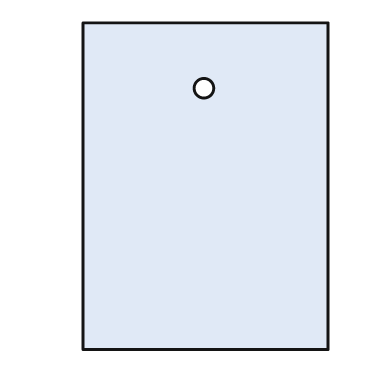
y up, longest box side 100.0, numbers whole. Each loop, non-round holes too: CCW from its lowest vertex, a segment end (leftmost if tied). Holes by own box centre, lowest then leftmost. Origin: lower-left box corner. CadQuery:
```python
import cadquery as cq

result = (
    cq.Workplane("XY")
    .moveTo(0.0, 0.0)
    .lineTo(75.0, 0.0)
    .lineTo(75.0, 100.0)
    .lineTo(0.0, 100.0)
    .close()
    .moveTo(37.0, 80.0)
    .circle(3.0)
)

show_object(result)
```